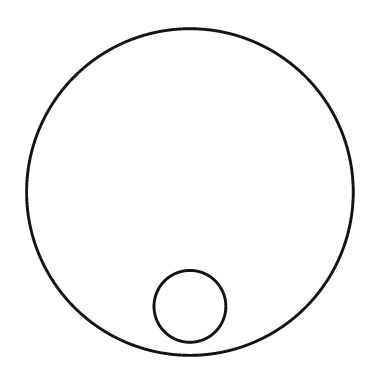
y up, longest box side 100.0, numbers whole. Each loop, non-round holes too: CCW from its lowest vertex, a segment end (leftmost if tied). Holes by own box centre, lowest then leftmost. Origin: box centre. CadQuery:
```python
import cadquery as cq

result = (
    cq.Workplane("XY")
    .moveTo(0.0, 0.0)
    .circle(50.0)
    .moveTo(0.0, -35.0)
    .circle(11.0)
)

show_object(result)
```